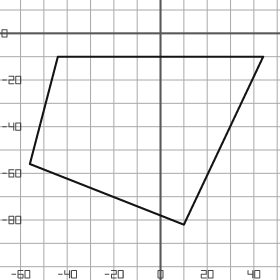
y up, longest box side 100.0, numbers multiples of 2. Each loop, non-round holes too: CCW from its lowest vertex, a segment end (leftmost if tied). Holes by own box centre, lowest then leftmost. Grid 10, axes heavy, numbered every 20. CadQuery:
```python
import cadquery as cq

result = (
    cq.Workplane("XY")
    .moveTo(10.0, -82.0)
    .lineTo(44.0, -10.0)
    .lineTo(-44.0, -10.0)
    .lineTo(-56.0, -56.0)
    .close()
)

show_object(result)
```